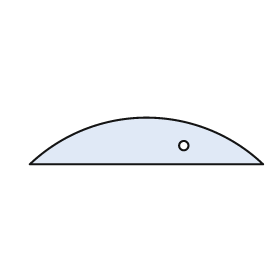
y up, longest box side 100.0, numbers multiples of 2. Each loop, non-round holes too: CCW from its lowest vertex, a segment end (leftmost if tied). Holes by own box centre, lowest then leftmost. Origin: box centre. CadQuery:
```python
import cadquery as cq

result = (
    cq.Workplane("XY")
    .moveTo(-50.0, -10.0)
    .lineTo(50.0, -10.0)
    .threePointArc((0.0, 10.0), (-50.0, -10.0))
    .close()
    .moveTo(16.0, -2.0)
    .circle(2.0)
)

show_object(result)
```